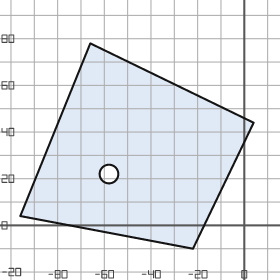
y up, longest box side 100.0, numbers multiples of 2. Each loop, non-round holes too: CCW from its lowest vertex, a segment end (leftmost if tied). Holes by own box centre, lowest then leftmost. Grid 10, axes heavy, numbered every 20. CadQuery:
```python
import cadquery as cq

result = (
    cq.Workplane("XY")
    .moveTo(-22.0, -10.0)
    .lineTo(4.0, 44.0)
    .lineTo(-66.0, 78.0)
    .lineTo(-96.0, 4.0)
    .close()
    .moveTo(-58.0, 22.0)
    .circle(4.0)
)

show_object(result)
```